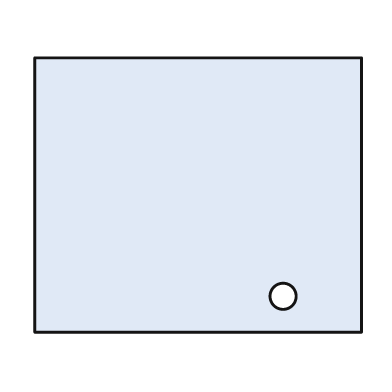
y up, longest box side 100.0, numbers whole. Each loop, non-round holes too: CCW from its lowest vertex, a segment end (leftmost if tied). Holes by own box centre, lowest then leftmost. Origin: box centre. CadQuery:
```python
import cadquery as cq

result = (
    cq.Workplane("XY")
    .moveTo(-50.0, -42.0)
    .lineTo(50.0, -42.0)
    .lineTo(50.0, 42.0)
    .lineTo(-50.0, 42.0)
    .close()
    .moveTo(26.0, -31.0)
    .circle(4.0)
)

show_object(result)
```